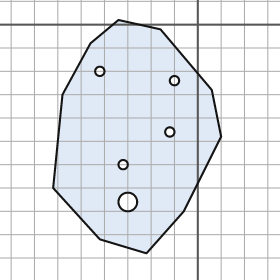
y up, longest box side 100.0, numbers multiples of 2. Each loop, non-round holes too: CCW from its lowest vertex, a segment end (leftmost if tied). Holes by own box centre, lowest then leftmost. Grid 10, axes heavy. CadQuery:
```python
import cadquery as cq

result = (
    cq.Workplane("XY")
    .moveTo(-22.0, -98.0)
    .lineTo(-6.0, -80.0)
    .lineTo(10.0, -48.0)
    .lineTo(6.0, -28.0)
    .lineTo(-16.0, -2.0)
    .lineTo(-34.0, 2.0)
    .lineTo(-46.0, -8.0)
    .lineTo(-58.0, -30.0)
    .lineTo(-62.0, -70.0)
    .lineTo(-42.0, -92.0)
    .close()
    .moveTo(-30.0, -76.0)
    .circle(4.0)
    .moveTo(-32.0, -60.0)
    .circle(2.0)
    .moveTo(-12.0, -46.0)
    .circle(2.0)
    .moveTo(-10.0, -24.0)
    .circle(2.0)
    .moveTo(-42.0, -20.0)
    .circle(2.0)
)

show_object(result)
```